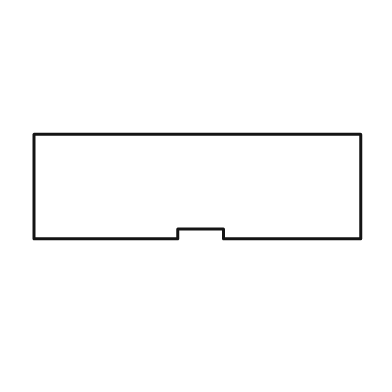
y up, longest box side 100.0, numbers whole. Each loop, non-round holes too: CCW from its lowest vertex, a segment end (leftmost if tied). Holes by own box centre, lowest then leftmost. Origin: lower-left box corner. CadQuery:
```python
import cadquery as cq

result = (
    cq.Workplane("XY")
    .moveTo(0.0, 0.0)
    .lineTo(44.0, 0.0)
    .lineTo(44.0, 3.0)
    .lineTo(58.0, 3.0)
    .lineTo(58.0, 0.0)
    .lineTo(100.0, 0.0)
    .lineTo(100.0, 32.0)
    .lineTo(0.0, 32.0)
    .close()
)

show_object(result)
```